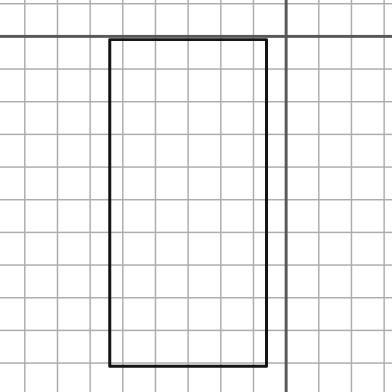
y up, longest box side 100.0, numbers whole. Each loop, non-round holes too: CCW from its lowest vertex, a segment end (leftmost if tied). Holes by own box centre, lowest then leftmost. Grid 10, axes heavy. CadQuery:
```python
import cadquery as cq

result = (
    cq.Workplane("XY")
    .moveTo(-54.0, -101.0)
    .lineTo(-6.0, -101.0)
    .lineTo(-6.0, -1.0)
    .lineTo(-54.0, -1.0)
    .close()
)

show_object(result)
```